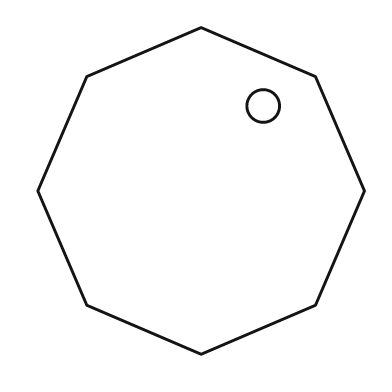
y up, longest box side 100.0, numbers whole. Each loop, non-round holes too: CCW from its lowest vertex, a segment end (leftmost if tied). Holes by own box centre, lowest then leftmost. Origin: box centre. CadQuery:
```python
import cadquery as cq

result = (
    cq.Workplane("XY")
    .moveTo(0.0, -50.0)
    .lineTo(35.0, -35.0)
    .lineTo(50.0, 0.0)
    .lineTo(35.0, 35.0)
    .lineTo(0.0, 50.0)
    .lineTo(-35.0, 35.0)
    .lineTo(-50.0, 0.0)
    .lineTo(-35.0, -35.0)
    .close()
    .moveTo(19.0, 26.0)
    .circle(5.0)
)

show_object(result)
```